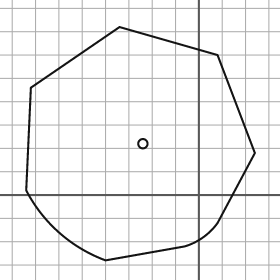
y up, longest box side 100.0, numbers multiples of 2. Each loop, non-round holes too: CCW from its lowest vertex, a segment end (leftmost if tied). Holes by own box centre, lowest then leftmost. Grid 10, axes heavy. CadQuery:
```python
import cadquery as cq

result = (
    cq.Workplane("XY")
    .moveTo(-40.0, -28.0)
    .lineTo(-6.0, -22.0)
    .threePointArc((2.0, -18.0), (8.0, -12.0))
    .lineTo(24.0, 18.0)
    .lineTo(8.0, 60.0)
    .lineTo(-34.0, 72.0)
    .lineTo(-72.0, 46.0)
    .lineTo(-74.0, 2.0)
    .threePointArc((-60.0, -16.0), (-40.0, -28.0))
    .close()
    .moveTo(-24.0, 22.0)
    .circle(2.0)
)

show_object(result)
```